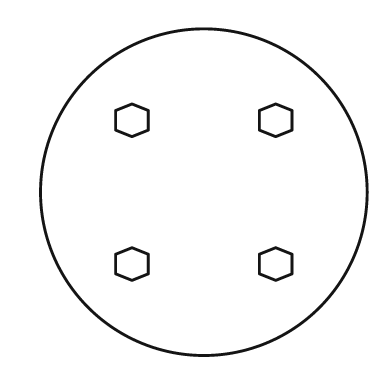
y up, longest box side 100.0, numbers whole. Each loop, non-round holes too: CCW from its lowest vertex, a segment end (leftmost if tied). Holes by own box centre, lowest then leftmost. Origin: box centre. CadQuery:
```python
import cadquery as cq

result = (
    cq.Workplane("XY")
    .moveTo(0.0, 0.0)
    .circle(50.0)
    .moveTo(-22.0, -27.0)
    .lineTo(-17.0, -25.0)
    .lineTo(-17.0, -19.0)
    .lineTo(-22.0, -17.0)
    .lineTo(-27.0, -19.0)
    .lineTo(-27.0, -25.0)
    .close()
    .moveTo(22.0, -27.0)
    .lineTo(27.0, -25.0)
    .lineTo(27.0, -19.0)
    .lineTo(22.0, -17.0)
    .lineTo(17.0, -19.0)
    .lineTo(17.0, -25.0)
    .close()
    .moveTo(-22.0, 17.0)
    .lineTo(-17.0, 19.0)
    .lineTo(-17.0, 25.0)
    .lineTo(-22.0, 27.0)
    .lineTo(-27.0, 25.0)
    .lineTo(-27.0, 19.0)
    .close()
    .moveTo(22.0, 17.0)
    .lineTo(27.0, 19.0)
    .lineTo(27.0, 25.0)
    .lineTo(22.0, 27.0)
    .lineTo(17.0, 25.0)
    .lineTo(17.0, 19.0)
    .close()
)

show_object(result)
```